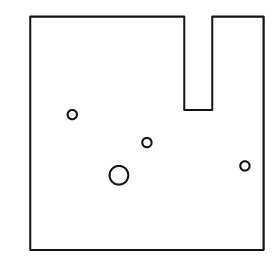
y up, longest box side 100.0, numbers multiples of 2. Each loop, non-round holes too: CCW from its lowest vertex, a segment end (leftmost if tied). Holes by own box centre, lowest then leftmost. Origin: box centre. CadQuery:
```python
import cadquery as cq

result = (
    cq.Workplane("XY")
    .moveTo(-50.0, -50.0)
    .lineTo(50.0, -50.0)
    .lineTo(50.0, 50.0)
    .lineTo(28.0, 50.0)
    .lineTo(28.0, 10.0)
    .lineTo(16.0, 10.0)
    .lineTo(16.0, 50.0)
    .lineTo(-50.0, 50.0)
    .close()
    .moveTo(-12.0, -18.0)
    .circle(4.0)
    .moveTo(42.0, -14.0)
    .circle(2.0)
    .moveTo(0.0, -4.0)
    .circle(2.0)
    .moveTo(-32.0, 8.0)
    .circle(2.0)
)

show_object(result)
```